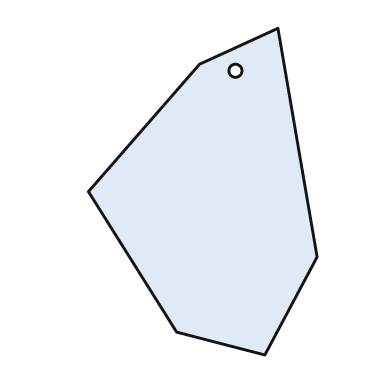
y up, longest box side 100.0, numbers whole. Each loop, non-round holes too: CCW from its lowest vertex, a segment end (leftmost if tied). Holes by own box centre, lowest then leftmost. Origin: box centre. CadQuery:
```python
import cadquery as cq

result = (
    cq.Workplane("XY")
    .moveTo(19.0, -50.0)
    .lineTo(35.0, -20.0)
    .lineTo(23.0, 50.0)
    .lineTo(-1.0, 39.0)
    .lineTo(-35.0, 0.0)
    .lineTo(-8.0, -43.0)
    .close()
    .moveTo(10.0, 37.0)
    .circle(2.0)
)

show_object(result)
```